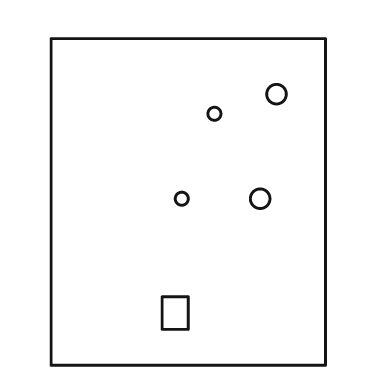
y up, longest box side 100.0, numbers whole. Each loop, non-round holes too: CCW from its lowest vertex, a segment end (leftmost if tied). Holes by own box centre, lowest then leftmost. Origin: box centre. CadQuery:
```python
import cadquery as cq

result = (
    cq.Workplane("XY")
    .moveTo(-42.0, -50.0)
    .lineTo(42.0, -50.0)
    .lineTo(42.0, 50.0)
    .lineTo(-42.0, 50.0)
    .close()
    .moveTo(-8.0, -39.0)
    .lineTo(0.0, -39.0)
    .lineTo(0.0, -29.0)
    .lineTo(-8.0, -29.0)
    .close()
    .moveTo(-2.0, 1.0)
    .circle(2.0)
    .moveTo(22.0, 1.0)
    .circle(3.0)
    .moveTo(8.0, 27.0)
    .circle(2.0)
    .moveTo(27.0, 33.0)
    .circle(3.0)
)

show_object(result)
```